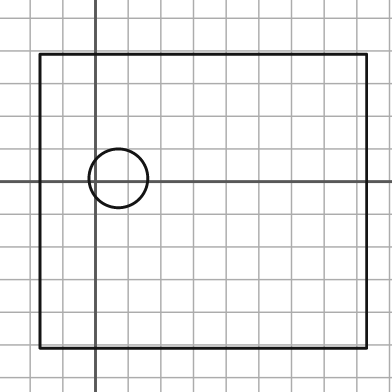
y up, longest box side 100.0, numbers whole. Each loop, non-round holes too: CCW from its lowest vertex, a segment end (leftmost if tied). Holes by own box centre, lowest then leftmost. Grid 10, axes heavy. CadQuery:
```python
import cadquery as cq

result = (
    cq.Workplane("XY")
    .moveTo(-17.0, -51.0)
    .lineTo(83.0, -51.0)
    .lineTo(83.0, 39.0)
    .lineTo(-17.0, 39.0)
    .close()
    .moveTo(7.0, 1.0)
    .circle(9.0)
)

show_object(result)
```